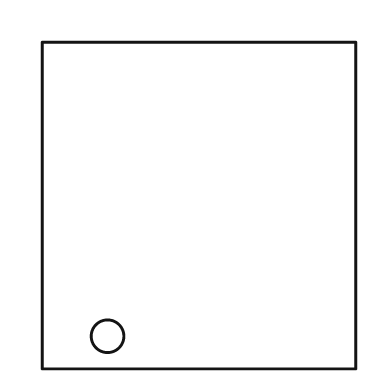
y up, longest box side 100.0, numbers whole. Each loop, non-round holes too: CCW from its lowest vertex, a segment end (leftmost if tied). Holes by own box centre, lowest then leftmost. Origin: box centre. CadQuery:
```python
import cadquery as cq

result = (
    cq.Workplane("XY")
    .moveTo(-48.0, -50.0)
    .lineTo(48.0, -50.0)
    .lineTo(48.0, 50.0)
    .lineTo(-48.0, 50.0)
    .close()
    .moveTo(-28.0, -40.0)
    .circle(5.0)
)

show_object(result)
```